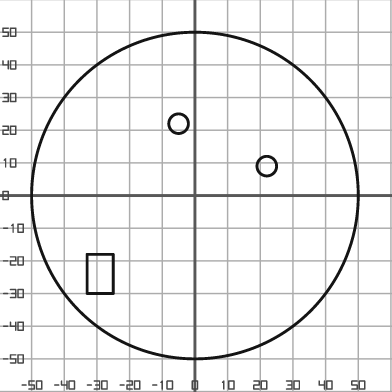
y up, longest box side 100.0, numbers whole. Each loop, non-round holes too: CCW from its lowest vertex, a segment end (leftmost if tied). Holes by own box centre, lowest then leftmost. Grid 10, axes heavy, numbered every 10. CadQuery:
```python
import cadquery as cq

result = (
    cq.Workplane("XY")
    .moveTo(0.0, 0.0)
    .circle(50.0)
    .moveTo(-33.0, -30.0)
    .lineTo(-25.0, -30.0)
    .lineTo(-25.0, -18.0)
    .lineTo(-33.0, -18.0)
    .close()
    .moveTo(22.0, 9.0)
    .circle(3.0)
    .moveTo(-5.0, 22.0)
    .circle(3.0)
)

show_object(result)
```